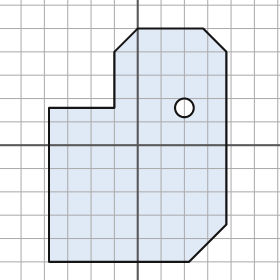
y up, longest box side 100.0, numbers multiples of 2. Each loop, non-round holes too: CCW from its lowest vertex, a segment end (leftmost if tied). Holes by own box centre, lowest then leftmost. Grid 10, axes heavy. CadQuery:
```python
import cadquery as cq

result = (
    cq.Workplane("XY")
    .moveTo(-38.0, -50.0)
    .lineTo(22.0, -50.0)
    .lineTo(38.0, -34.0)
    .lineTo(38.0, 40.0)
    .lineTo(28.0, 50.0)
    .lineTo(0.0, 50.0)
    .lineTo(-10.0, 40.0)
    .lineTo(-10.0, 16.0)
    .lineTo(-38.0, 16.0)
    .close()
    .moveTo(20.0, 16.0)
    .circle(4.0)
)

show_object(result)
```